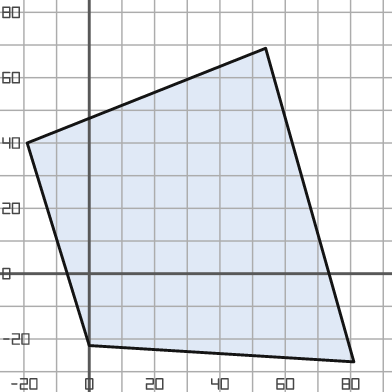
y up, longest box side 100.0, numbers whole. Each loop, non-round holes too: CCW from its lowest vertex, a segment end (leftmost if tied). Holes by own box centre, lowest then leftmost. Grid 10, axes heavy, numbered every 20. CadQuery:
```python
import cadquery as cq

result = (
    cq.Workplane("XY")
    .moveTo(81.0, -27.0)
    .lineTo(54.0, 69.0)
    .lineTo(-19.0, 40.0)
    .lineTo(0.0, -22.0)
    .close()
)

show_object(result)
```